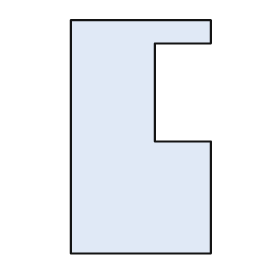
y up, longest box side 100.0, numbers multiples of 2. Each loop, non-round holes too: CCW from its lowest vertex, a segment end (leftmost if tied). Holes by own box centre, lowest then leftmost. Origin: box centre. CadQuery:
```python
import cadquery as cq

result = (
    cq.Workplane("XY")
    .moveTo(-30.0, -50.0)
    .lineTo(30.0, -50.0)
    .lineTo(30.0, -2.0)
    .lineTo(6.0, -2.0)
    .lineTo(6.0, 40.0)
    .lineTo(30.0, 40.0)
    .lineTo(30.0, 50.0)
    .lineTo(-30.0, 50.0)
    .close()
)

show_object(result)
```